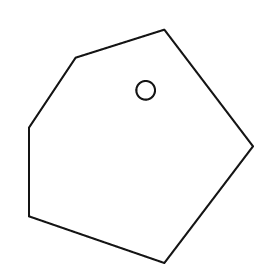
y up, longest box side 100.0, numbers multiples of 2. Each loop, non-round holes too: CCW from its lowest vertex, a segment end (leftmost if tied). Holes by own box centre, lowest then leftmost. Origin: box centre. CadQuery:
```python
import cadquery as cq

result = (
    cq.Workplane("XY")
    .moveTo(10.0, -50.0)
    .lineTo(48.0, 0.0)
    .lineTo(10.0, 50.0)
    .lineTo(-28.0, 38.0)
    .lineTo(-48.0, 8.0)
    .lineTo(-48.0, -30.0)
    .close()
    .moveTo(2.0, 24.0)
    .circle(4.0)
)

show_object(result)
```